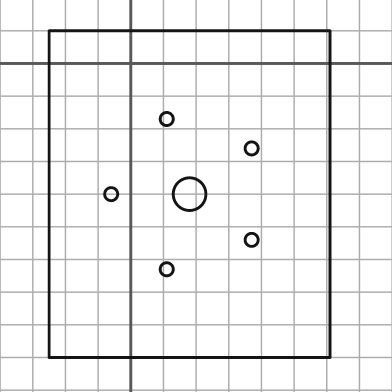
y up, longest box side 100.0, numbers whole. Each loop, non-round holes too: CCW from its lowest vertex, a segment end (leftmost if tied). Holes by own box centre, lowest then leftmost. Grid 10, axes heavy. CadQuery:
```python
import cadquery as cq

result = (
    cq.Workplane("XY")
    .moveTo(-25.0, -90.0)
    .lineTo(61.0, -90.0)
    .lineTo(61.0, 10.0)
    .lineTo(-25.0, 10.0)
    .close()
    .moveTo(11.0, -63.0)
    .circle(2.0)
    .moveTo(37.0, -54.0)
    .circle(2.0)
    .moveTo(-6.0, -40.0)
    .circle(2.0)
    .moveTo(18.0, -40.0)
    .circle(5.0)
    .moveTo(37.0, -26.0)
    .circle(2.0)
    .moveTo(11.0, -17.0)
    .circle(2.0)
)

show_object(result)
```